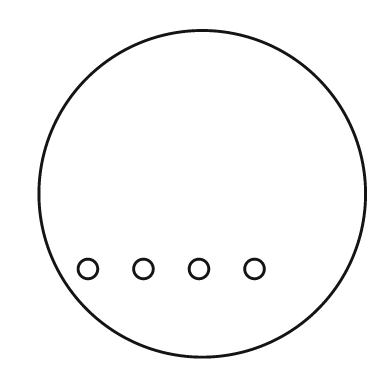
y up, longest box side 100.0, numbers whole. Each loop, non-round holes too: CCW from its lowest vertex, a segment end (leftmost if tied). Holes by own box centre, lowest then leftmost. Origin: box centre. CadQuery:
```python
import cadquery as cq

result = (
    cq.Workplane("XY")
    .moveTo(0.0, 0.0)
    .circle(50.0)
    .moveTo(-35.0, -23.0)
    .circle(3.0)
    .moveTo(-18.0, -23.0)
    .circle(3.0)
    .moveTo(-1.0, -23.0)
    .circle(3.0)
    .moveTo(16.0, -23.0)
    .circle(3.0)
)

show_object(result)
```